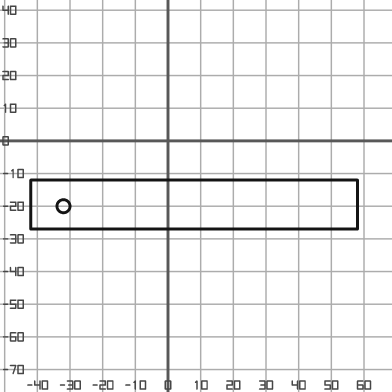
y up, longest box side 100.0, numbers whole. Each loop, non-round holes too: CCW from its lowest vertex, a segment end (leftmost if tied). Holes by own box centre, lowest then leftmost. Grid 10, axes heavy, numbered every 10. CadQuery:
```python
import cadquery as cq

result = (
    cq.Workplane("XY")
    .moveTo(-42.0, -27.0)
    .lineTo(58.0, -27.0)
    .lineTo(58.0, -12.0)
    .lineTo(-42.0, -12.0)
    .close()
    .moveTo(-32.0, -20.0)
    .circle(2.0)
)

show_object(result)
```